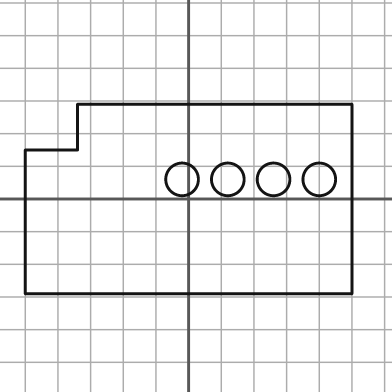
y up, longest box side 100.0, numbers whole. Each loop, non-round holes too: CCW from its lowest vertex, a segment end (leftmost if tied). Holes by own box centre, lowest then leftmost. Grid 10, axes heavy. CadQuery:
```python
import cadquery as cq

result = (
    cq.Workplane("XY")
    .moveTo(-50.0, -29.0)
    .lineTo(50.0, -29.0)
    .lineTo(50.0, 29.0)
    .lineTo(-34.0, 29.0)
    .lineTo(-34.0, 15.0)
    .lineTo(-50.0, 15.0)
    .close()
    .moveTo(-2.0, 6.0)
    .circle(5.0)
    .moveTo(12.0, 6.0)
    .circle(5.0)
    .moveTo(26.0, 6.0)
    .circle(5.0)
    .moveTo(40.0, 6.0)
    .circle(5.0)
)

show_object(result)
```